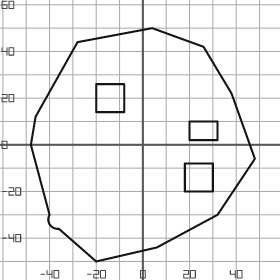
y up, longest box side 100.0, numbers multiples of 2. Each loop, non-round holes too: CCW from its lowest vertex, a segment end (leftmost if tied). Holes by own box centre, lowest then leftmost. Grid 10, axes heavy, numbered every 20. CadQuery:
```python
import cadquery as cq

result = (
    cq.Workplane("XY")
    .moveTo(-20.0, -50.0)
    .lineTo(6.0, -44.0)
    .lineTo(32.0, -30.0)
    .lineTo(48.0, -6.0)
    .lineTo(38.0, 22.0)
    .lineTo(26.0, 42.0)
    .lineTo(4.0, 50.0)
    .lineTo(-28.0, 44.0)
    .lineTo(-46.0, 12.0)
    .lineTo(-48.0, 0.0)
    .lineTo(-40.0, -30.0)
    .threePointArc((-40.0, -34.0), (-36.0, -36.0))
    .close()
    .moveTo(18.0, -20.0)
    .lineTo(30.0, -20.0)
    .lineTo(30.0, -8.0)
    .lineTo(18.0, -8.0)
    .close()
    .moveTo(20.0, 2.0)
    .lineTo(32.0, 2.0)
    .lineTo(32.0, 10.0)
    .lineTo(20.0, 10.0)
    .close()
    .moveTo(-20.0, 14.0)
    .lineTo(-8.0, 14.0)
    .lineTo(-8.0, 26.0)
    .lineTo(-20.0, 26.0)
    .close()
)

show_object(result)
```